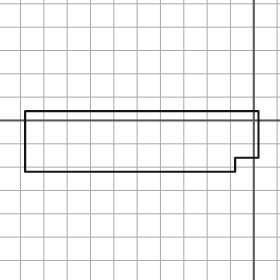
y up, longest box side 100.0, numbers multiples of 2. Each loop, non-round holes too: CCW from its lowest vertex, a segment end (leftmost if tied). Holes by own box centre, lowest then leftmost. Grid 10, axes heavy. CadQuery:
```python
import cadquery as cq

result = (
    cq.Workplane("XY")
    .moveTo(-98.0, -22.0)
    .lineTo(-8.0, -22.0)
    .lineTo(-8.0, -16.0)
    .lineTo(2.0, -16.0)
    .lineTo(2.0, 4.0)
    .lineTo(-98.0, 4.0)
    .close()
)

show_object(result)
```